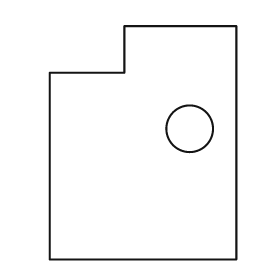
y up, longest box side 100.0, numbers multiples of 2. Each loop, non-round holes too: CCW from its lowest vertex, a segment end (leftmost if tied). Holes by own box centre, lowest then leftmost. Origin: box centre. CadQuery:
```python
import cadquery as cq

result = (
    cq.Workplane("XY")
    .moveTo(-40.0, -50.0)
    .lineTo(40.0, -50.0)
    .lineTo(40.0, 50.0)
    .lineTo(-8.0, 50.0)
    .lineTo(-8.0, 30.0)
    .lineTo(-40.0, 30.0)
    .close()
    .moveTo(20.0, 6.0)
    .circle(10.0)
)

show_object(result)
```